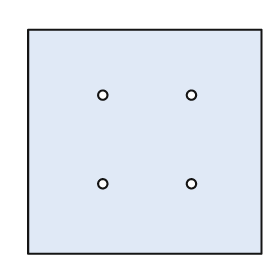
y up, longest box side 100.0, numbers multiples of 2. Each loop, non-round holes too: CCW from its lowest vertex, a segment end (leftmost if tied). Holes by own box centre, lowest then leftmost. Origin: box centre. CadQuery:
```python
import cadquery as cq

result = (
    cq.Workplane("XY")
    .moveTo(-50.0, -48.0)
    .lineTo(50.0, -48.0)
    .lineTo(50.0, 48.0)
    .lineTo(-50.0, 48.0)
    .close()
    .moveTo(-18.0, -18.0)
    .circle(2.0)
    .moveTo(20.0, -18.0)
    .circle(2.0)
    .moveTo(-18.0, 20.0)
    .circle(2.0)
    .moveTo(20.0, 20.0)
    .circle(2.0)
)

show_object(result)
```